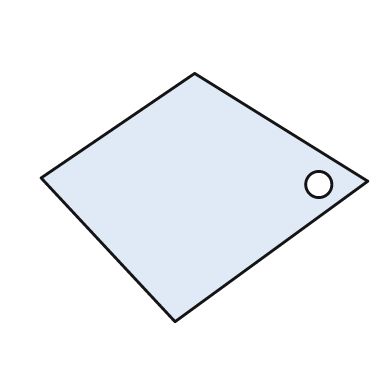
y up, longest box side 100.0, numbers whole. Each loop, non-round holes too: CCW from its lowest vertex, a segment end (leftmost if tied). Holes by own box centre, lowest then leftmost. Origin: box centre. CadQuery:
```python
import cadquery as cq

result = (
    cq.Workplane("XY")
    .moveTo(-9.0, -38.0)
    .lineTo(50.0, 5.0)
    .lineTo(-3.0, 38.0)
    .lineTo(-50.0, 6.0)
    .close()
    .moveTo(35.0, 4.0)
    .circle(4.0)
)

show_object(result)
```